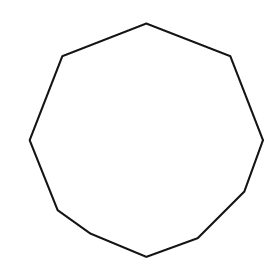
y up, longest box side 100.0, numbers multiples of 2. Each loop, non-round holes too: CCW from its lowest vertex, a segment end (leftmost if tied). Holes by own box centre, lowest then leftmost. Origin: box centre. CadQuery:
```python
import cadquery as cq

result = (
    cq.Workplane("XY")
    .moveTo(0.0, -50.0)
    .lineTo(22.0, -42.0)
    .lineTo(42.0, -22.0)
    .lineTo(50.0, 0.0)
    .lineTo(36.0, 36.0)
    .lineTo(0.0, 50.0)
    .lineTo(-36.0, 36.0)
    .lineTo(-50.0, 0.0)
    .lineTo(-38.0, -30.0)
    .lineTo(-24.0, -40.0)
    .close()
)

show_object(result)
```